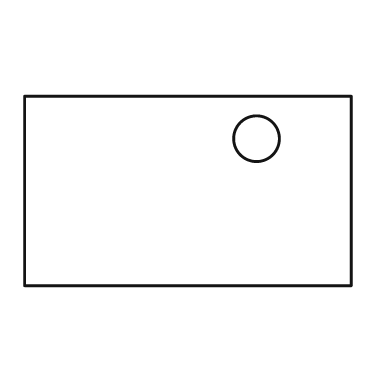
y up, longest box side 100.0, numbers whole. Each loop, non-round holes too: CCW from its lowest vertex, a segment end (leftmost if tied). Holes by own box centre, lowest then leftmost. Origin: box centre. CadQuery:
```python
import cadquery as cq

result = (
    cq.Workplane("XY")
    .moveTo(-50.0, -29.0)
    .lineTo(50.0, -29.0)
    .lineTo(50.0, 29.0)
    .lineTo(-50.0, 29.0)
    .close()
    .moveTo(21.0, 16.0)
    .circle(7.0)
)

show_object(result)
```